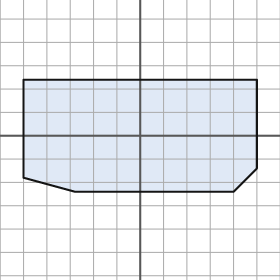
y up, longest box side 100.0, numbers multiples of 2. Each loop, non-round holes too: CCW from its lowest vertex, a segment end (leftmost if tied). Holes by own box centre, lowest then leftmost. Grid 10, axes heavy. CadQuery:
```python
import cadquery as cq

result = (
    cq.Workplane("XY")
    .moveTo(-28.0, -24.0)
    .lineTo(40.0, -24.0)
    .lineTo(50.0, -14.0)
    .lineTo(50.0, 24.0)
    .lineTo(-50.0, 24.0)
    .lineTo(-50.0, -18.0)
    .close()
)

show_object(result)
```